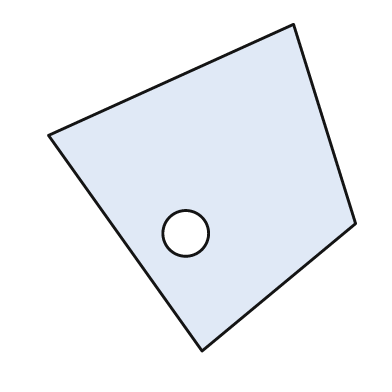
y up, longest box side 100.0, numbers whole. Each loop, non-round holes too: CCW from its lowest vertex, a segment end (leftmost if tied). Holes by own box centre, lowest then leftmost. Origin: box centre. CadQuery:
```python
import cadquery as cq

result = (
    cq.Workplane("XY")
    .moveTo(0.0, -50.0)
    .lineTo(47.0, -11.0)
    .lineTo(28.0, 50.0)
    .lineTo(-47.0, 16.0)
    .close()
    .moveTo(-5.0, -14.0)
    .circle(7.0)
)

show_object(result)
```